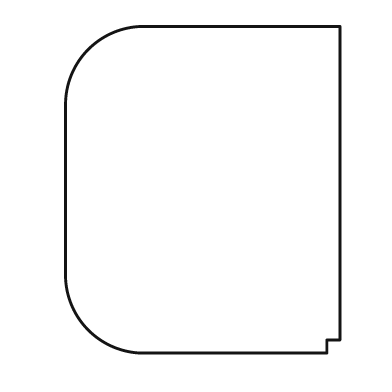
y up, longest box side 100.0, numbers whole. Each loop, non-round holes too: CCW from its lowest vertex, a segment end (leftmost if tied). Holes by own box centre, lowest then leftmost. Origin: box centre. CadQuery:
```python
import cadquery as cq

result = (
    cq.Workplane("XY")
    .moveTo(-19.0, -50.0)
    .lineTo(38.0, -50.0)
    .lineTo(38.0, -46.0)
    .lineTo(42.0, -46.0)
    .lineTo(42.0, 50.0)
    .lineTo(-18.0, 50.0)
    .threePointArc((-35.0, 43.0), (-42.0, 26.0))
    .lineTo(-42.0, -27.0)
    .threePointArc((-35.0, -43.0), (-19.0, -50.0))
    .close()
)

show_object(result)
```